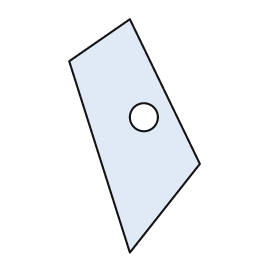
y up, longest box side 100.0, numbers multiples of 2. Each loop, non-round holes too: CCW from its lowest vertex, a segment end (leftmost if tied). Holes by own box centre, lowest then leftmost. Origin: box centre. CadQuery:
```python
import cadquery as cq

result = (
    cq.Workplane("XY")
    .moveTo(-2.0, -50.0)
    .lineTo(28.0, -12.0)
    .lineTo(-2.0, 50.0)
    .lineTo(-28.0, 32.0)
    .close()
    .moveTo(4.0, 8.0)
    .circle(6.0)
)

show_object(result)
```